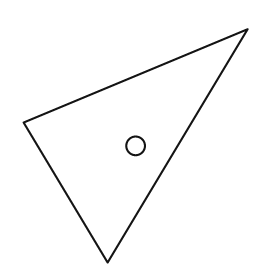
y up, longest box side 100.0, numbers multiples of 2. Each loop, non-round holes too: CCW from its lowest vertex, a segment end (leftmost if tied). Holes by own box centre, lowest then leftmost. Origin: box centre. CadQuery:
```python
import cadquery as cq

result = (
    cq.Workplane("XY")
    .moveTo(-12.0, -50.0)
    .lineTo(48.0, 50.0)
    .lineTo(-48.0, 10.0)
    .close()
    .moveTo(0.0, 0.0)
    .circle(4.0)
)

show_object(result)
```